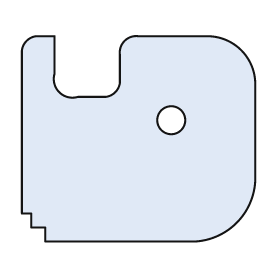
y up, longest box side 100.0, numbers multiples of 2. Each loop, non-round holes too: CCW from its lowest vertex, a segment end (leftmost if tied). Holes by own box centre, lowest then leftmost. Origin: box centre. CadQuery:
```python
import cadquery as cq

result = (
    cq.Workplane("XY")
    .moveTo(-40.0, -44.0)
    .lineTo(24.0, -44.0)
    .threePointArc((42.0, -36.0), (50.0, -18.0))
    .lineTo(50.0, 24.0)
    .threePointArc((44.0, 38.0), (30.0, 44.0))
    .lineTo(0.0, 44.0)
    .threePointArc((-6.0, 42.0), (-8.0, 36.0))
    .lineTo(-8.0, 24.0)
    .threePointArc((-10.0, 20.0), (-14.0, 18.0))
    .lineTo(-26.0, 18.0)
    .threePointArc((-34.0, 20.0), (-36.0, 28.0))
    .lineTo(-36.0, 44.0)
    .lineTo(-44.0, 44.0)
    .threePointArc((-48.0, 42.0), (-50.0, 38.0))
    .lineTo(-50.0, -32.0)
    .lineTo(-46.0, -32.0)
    .lineTo(-46.0, -38.0)
    .lineTo(-40.0, -38.0)
    .close()
    .moveTo(14.0, 8.0)
    .circle(6.0)
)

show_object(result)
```